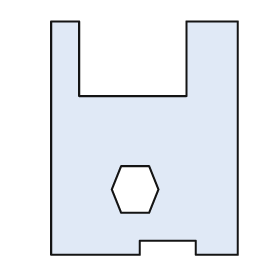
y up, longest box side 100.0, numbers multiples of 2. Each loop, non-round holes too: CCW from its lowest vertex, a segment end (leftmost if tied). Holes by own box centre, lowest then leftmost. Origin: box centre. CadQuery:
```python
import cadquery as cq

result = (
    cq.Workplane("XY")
    .moveTo(-40.0, -50.0)
    .lineTo(-2.0, -50.0)
    .lineTo(-2.0, -44.0)
    .lineTo(22.0, -44.0)
    .lineTo(22.0, -50.0)
    .lineTo(40.0, -50.0)
    .lineTo(40.0, 50.0)
    .lineTo(18.0, 50.0)
    .lineTo(18.0, 18.0)
    .lineTo(-28.0, 18.0)
    .lineTo(-28.0, 50.0)
    .lineTo(-40.0, 50.0)
    .close()
    .moveTo(-10.0, -32.0)
    .lineTo(2.0, -32.0)
    .lineTo(6.0, -22.0)
    .lineTo(2.0, -12.0)
    .lineTo(-10.0, -12.0)
    .lineTo(-14.0, -22.0)
    .close()
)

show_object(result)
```